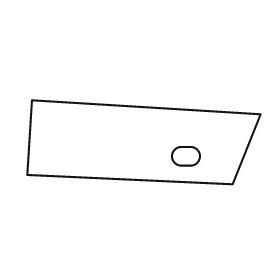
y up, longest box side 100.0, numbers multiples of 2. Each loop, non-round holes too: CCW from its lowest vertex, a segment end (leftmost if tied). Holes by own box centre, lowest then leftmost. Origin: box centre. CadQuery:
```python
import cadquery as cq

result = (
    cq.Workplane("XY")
    .moveTo(38.0, -18.0)
    .lineTo(50.0, 12.0)
    .lineTo(-48.0, 18.0)
    .lineTo(-50.0, -14.0)
    .close()
    .moveTo(16.0, -10.0)
    .lineTo(20.0, -10.0)
    .threePointArc((24.0, -6.0), (20.0, -2.0))
    .lineTo(16.0, -2.0)
    .threePointArc((12.0, -6.0), (16.0, -10.0))
    .close()
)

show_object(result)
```